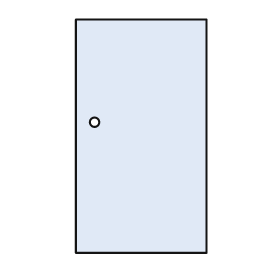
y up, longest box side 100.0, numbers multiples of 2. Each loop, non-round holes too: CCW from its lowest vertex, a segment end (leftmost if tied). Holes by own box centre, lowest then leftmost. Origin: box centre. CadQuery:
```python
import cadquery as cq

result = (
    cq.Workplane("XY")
    .moveTo(-28.0, -50.0)
    .lineTo(28.0, -50.0)
    .lineTo(28.0, 50.0)
    .lineTo(-28.0, 50.0)
    .close()
    .moveTo(-20.0, 6.0)
    .circle(2.0)
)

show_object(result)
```